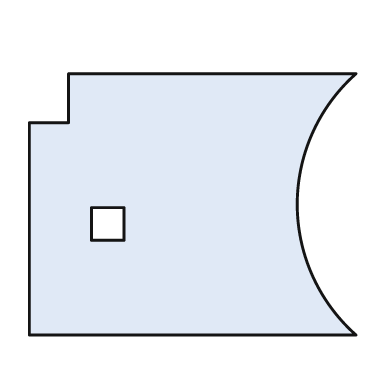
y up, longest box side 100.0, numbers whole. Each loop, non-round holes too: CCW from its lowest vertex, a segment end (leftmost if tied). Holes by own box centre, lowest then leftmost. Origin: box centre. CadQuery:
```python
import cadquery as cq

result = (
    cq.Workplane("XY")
    .moveTo(-50.0, -40.0)
    .lineTo(50.0, -40.0)
    .threePointArc((32.0, 0.0), (50.0, 40.0))
    .lineTo(-38.0, 40.0)
    .lineTo(-38.0, 25.0)
    .lineTo(-50.0, 25.0)
    .close()
    .moveTo(-31.0, -11.0)
    .lineTo(-21.0, -11.0)
    .lineTo(-21.0, -1.0)
    .lineTo(-31.0, -1.0)
    .close()
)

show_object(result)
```